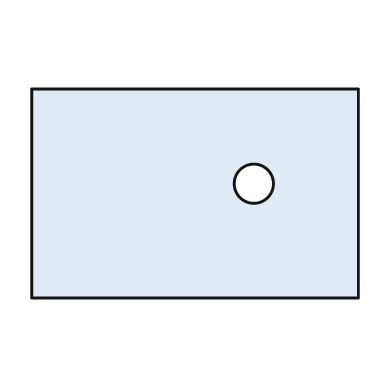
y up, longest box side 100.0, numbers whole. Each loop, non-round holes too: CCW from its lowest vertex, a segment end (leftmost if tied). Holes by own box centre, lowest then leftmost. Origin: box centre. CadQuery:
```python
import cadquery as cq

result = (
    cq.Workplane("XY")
    .moveTo(-50.0, -32.0)
    .lineTo(50.0, -32.0)
    .lineTo(50.0, 32.0)
    .lineTo(-50.0, 32.0)
    .close()
    .moveTo(18.0, 3.0)
    .circle(6.0)
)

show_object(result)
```